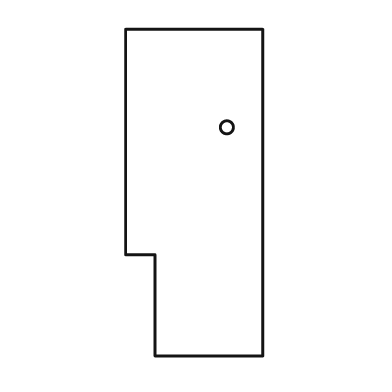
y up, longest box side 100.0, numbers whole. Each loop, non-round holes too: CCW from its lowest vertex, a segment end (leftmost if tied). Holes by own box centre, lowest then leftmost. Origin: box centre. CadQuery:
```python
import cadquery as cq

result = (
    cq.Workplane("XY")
    .moveTo(-12.0, -50.0)
    .lineTo(21.0, -50.0)
    .lineTo(21.0, 50.0)
    .lineTo(-21.0, 50.0)
    .lineTo(-21.0, -19.0)
    .lineTo(-12.0, -19.0)
    .close()
    .moveTo(10.0, 20.0)
    .circle(2.0)
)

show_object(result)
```